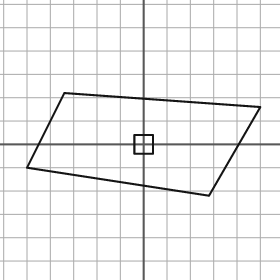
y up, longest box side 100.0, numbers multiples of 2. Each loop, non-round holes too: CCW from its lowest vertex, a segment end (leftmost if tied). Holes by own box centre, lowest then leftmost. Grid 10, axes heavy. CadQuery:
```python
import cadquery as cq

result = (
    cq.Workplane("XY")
    .moveTo(28.0, -22.0)
    .lineTo(50.0, 16.0)
    .lineTo(-34.0, 22.0)
    .lineTo(-50.0, -10.0)
    .close()
    .moveTo(-4.0, -4.0)
    .lineTo(4.0, -4.0)
    .lineTo(4.0, 4.0)
    .lineTo(-4.0, 4.0)
    .close()
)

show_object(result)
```